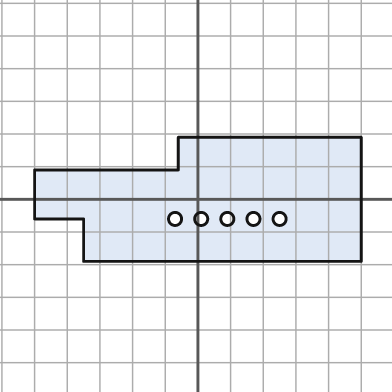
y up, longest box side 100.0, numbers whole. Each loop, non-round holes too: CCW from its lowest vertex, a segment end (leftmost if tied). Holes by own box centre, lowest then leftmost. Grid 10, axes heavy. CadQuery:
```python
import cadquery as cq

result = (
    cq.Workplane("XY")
    .moveTo(-35.0, -19.0)
    .lineTo(50.0, -19.0)
    .lineTo(50.0, 19.0)
    .lineTo(-6.0, 19.0)
    .lineTo(-6.0, 9.0)
    .lineTo(-50.0, 9.0)
    .lineTo(-50.0, -6.0)
    .lineTo(-35.0, -6.0)
    .close()
    .moveTo(-7.0, -6.0)
    .circle(2.0)
    .moveTo(1.0, -6.0)
    .circle(2.0)
    .moveTo(9.0, -6.0)
    .circle(2.0)
    .moveTo(17.0, -6.0)
    .circle(2.0)
    .moveTo(25.0, -6.0)
    .circle(2.0)
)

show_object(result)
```